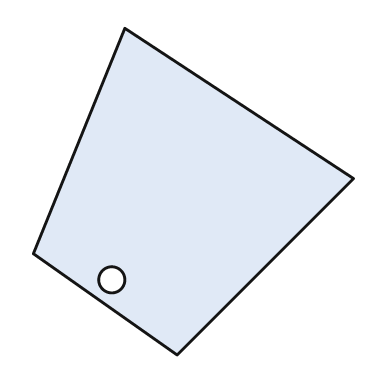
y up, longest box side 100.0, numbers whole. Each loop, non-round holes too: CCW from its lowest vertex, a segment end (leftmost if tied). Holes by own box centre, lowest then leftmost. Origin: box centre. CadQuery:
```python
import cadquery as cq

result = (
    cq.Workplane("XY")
    .moveTo(-5.0, -50.0)
    .lineTo(49.0, 4.0)
    .lineTo(-21.0, 50.0)
    .lineTo(-49.0, -19.0)
    .close()
    .moveTo(-25.0, -27.0)
    .circle(4.0)
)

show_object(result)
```